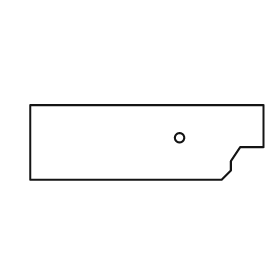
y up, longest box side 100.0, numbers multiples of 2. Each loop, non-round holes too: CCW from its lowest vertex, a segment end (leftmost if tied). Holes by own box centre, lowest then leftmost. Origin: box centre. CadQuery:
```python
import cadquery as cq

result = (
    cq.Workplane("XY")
    .moveTo(-50.0, -16.0)
    .lineTo(32.0, -16.0)
    .lineTo(36.0, -12.0)
    .lineTo(36.0, -8.0)
    .lineTo(40.0, -2.0)
    .lineTo(50.0, -2.0)
    .lineTo(50.0, 16.0)
    .lineTo(-50.0, 16.0)
    .close()
    .moveTo(14.0, 2.0)
    .circle(2.0)
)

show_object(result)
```